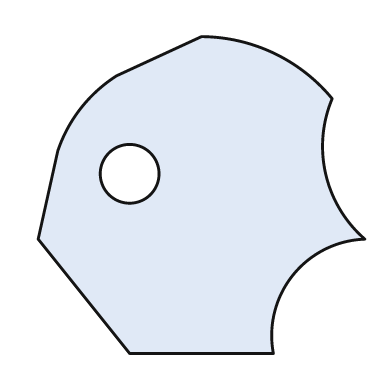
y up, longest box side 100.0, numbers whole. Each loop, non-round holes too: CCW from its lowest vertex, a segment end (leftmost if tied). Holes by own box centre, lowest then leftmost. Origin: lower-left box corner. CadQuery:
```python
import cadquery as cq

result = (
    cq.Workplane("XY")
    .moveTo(28.0, 0.0)
    .lineTo(72.0, 0.0)
    .threePointArc((78.0, 24.0), (100.0, 35.0))
    .threePointArc((88.0, 55.0), (90.0, 78.0))
    .threePointArc((72.0, 92.0), (50.0, 97.0))
    .lineTo(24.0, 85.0)
    .threePointArc((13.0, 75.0), (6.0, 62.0))
    .lineTo(0.0, 35.0)
    .close()
    .moveTo(28.0, 55.0)
    .circle(9.0)
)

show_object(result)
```